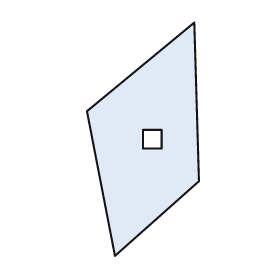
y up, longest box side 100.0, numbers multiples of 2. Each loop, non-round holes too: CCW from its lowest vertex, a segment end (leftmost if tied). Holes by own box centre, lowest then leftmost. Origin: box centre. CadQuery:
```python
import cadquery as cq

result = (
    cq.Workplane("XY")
    .moveTo(-12.0, -50.0)
    .lineTo(24.0, -18.0)
    .lineTo(22.0, 50.0)
    .lineTo(-24.0, 12.0)
    .close()
    .moveTo(0.0, -4.0)
    .lineTo(8.0, -4.0)
    .lineTo(8.0, 4.0)
    .lineTo(0.0, 4.0)
    .close()
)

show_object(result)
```